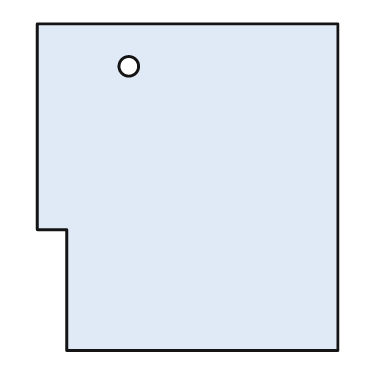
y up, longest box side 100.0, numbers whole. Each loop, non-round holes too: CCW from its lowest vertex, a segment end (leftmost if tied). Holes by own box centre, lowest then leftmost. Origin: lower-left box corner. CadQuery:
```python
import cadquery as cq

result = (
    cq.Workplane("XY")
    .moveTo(9.0, 0.0)
    .lineTo(92.0, 0.0)
    .lineTo(92.0, 100.0)
    .lineTo(0.0, 100.0)
    .lineTo(0.0, 37.0)
    .lineTo(9.0, 37.0)
    .close()
    .moveTo(28.0, 87.0)
    .circle(3.0)
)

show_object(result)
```